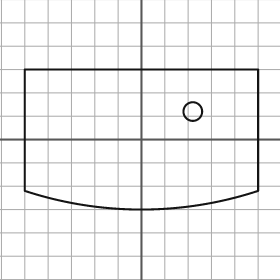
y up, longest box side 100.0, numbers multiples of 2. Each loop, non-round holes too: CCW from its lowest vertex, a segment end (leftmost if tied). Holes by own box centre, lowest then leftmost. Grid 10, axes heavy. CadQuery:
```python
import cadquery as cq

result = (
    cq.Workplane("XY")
    .moveTo(-50.0, -22.0)
    .threePointArc((0.0, -30.0), (50.0, -22.0))
    .lineTo(50.0, 30.0)
    .lineTo(-50.0, 30.0)
    .close()
    .moveTo(22.0, 12.0)
    .circle(4.0)
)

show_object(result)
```